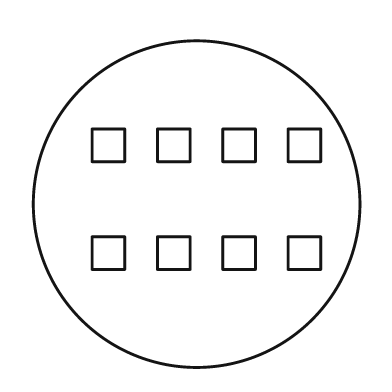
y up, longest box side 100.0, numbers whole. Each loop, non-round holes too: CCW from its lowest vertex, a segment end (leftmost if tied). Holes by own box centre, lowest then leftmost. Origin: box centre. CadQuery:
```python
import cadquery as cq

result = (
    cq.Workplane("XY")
    .moveTo(0.0, 0.0)
    .circle(50.0)
    .moveTo(-32.0, -20.0)
    .lineTo(-22.0, -20.0)
    .lineTo(-22.0, -10.0)
    .lineTo(-32.0, -10.0)
    .close()
    .moveTo(-12.0, -20.0)
    .lineTo(-2.0, -20.0)
    .lineTo(-2.0, -10.0)
    .lineTo(-12.0, -10.0)
    .close()
    .moveTo(8.0, -20.0)
    .lineTo(18.0, -20.0)
    .lineTo(18.0, -10.0)
    .lineTo(8.0, -10.0)
    .close()
    .moveTo(28.0, -20.0)
    .lineTo(38.0, -20.0)
    .lineTo(38.0, -10.0)
    .lineTo(28.0, -10.0)
    .close()
    .moveTo(-32.0, 13.0)
    .lineTo(-22.0, 13.0)
    .lineTo(-22.0, 23.0)
    .lineTo(-32.0, 23.0)
    .close()
    .moveTo(-12.0, 13.0)
    .lineTo(-2.0, 13.0)
    .lineTo(-2.0, 23.0)
    .lineTo(-12.0, 23.0)
    .close()
    .moveTo(8.0, 13.0)
    .lineTo(18.0, 13.0)
    .lineTo(18.0, 23.0)
    .lineTo(8.0, 23.0)
    .close()
    .moveTo(28.0, 13.0)
    .lineTo(38.0, 13.0)
    .lineTo(38.0, 23.0)
    .lineTo(28.0, 23.0)
    .close()
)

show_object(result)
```